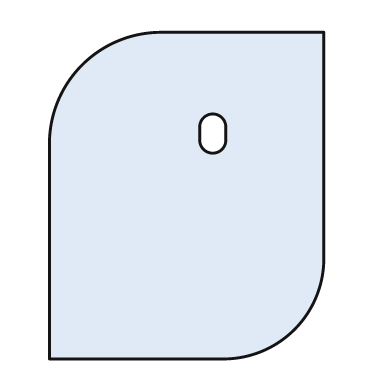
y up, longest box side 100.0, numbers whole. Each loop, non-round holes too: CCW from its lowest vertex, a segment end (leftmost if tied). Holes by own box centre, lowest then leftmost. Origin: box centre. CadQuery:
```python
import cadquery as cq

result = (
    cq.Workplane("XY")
    .moveTo(-42.0, -50.0)
    .lineTo(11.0, -50.0)
    .threePointArc((33.0, -41.0), (42.0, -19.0))
    .lineTo(42.0, 50.0)
    .lineTo(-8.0, 50.0)
    .threePointArc((-32.0, 40.0), (-42.0, 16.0))
    .close()
    .moveTo(4.0, 17.0)
    .threePointArc((8.0, 13.0), (12.0, 17.0))
    .lineTo(12.0, 21.0)
    .threePointArc((8.0, 25.0), (4.0, 21.0))
    .close()
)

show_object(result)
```